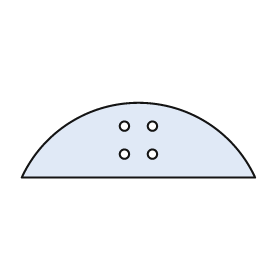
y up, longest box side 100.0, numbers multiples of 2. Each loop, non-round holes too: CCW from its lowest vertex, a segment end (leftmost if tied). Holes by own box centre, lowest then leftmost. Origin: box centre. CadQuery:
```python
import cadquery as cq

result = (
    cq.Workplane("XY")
    .moveTo(-50.0, -16.0)
    .lineTo(50.0, -16.0)
    .threePointArc((0.0, 16.0), (-50.0, -16.0))
    .close()
    .moveTo(-6.0, -6.0)
    .circle(2.0)
    .moveTo(6.0, -6.0)
    .circle(2.0)
    .moveTo(-6.0, 6.0)
    .circle(2.0)
    .moveTo(6.0, 6.0)
    .circle(2.0)
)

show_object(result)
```